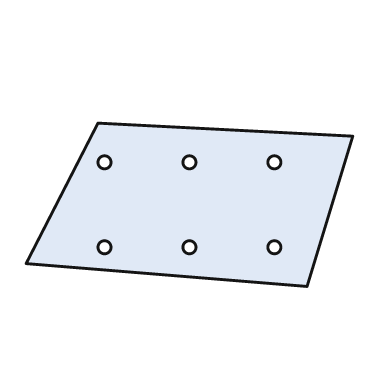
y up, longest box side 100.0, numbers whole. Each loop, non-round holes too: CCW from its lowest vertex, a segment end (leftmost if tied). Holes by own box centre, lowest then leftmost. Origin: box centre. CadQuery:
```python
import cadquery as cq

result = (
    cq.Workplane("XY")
    .moveTo(36.0, -25.0)
    .lineTo(50.0, 21.0)
    .lineTo(-28.0, 25.0)
    .lineTo(-50.0, -18.0)
    .close()
    .moveTo(-26.0, -13.0)
    .circle(2.0)
    .moveTo(0.0, -13.0)
    .circle(2.0)
    .moveTo(26.0, -13.0)
    .circle(2.0)
    .moveTo(-26.0, 13.0)
    .circle(2.0)
    .moveTo(0.0, 13.0)
    .circle(2.0)
    .moveTo(26.0, 13.0)
    .circle(2.0)
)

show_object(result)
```